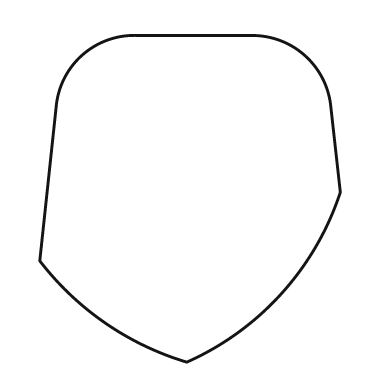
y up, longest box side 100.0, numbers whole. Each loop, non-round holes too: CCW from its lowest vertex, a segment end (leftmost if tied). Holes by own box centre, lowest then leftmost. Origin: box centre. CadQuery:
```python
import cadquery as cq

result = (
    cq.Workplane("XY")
    .moveTo(-1.0, -50.0)
    .threePointArc((28.0, -29.0), (46.0, 2.0))
    .lineTo(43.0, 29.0)
    .threePointArc((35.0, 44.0), (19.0, 50.0))
    .lineTo(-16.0, 50.0)
    .threePointArc((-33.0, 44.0), (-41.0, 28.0))
    .lineTo(-46.0, -19.0)
    .threePointArc((-26.0, -38.0), (-1.0, -50.0))
    .close()
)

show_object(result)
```